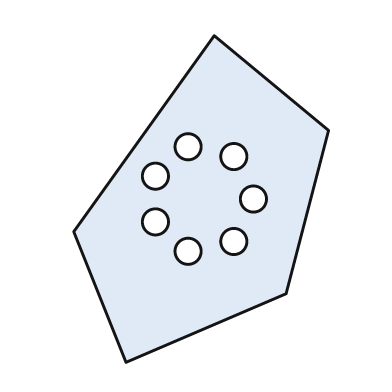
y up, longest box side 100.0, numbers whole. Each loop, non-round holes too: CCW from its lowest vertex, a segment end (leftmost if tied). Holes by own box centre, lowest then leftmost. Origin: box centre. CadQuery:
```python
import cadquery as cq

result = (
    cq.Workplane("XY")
    .moveTo(-23.0, -50.0)
    .lineTo(26.0, -29.0)
    .lineTo(39.0, 21.0)
    .lineTo(4.0, 50.0)
    .lineTo(-39.0, -10.0)
    .close()
    .moveTo(-4.0, -16.0)
    .circle(4.0)
    .moveTo(10.0, -13.0)
    .circle(4.0)
    .moveTo(-14.0, -7.0)
    .circle(4.0)
    .moveTo(16.0, 0.0)
    .circle(4.0)
    .moveTo(-14.0, 7.0)
    .circle(4.0)
    .moveTo(10.0, 13.0)
    .circle(4.0)
    .moveTo(-4.0, 16.0)
    .circle(4.0)
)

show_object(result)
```